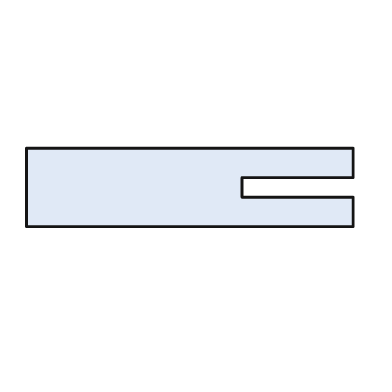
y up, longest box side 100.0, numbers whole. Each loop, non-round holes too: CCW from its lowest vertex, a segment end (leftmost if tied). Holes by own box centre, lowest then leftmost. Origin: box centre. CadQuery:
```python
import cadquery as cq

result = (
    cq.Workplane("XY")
    .moveTo(-50.0, -12.0)
    .lineTo(50.0, -12.0)
    .lineTo(50.0, -3.0)
    .lineTo(16.0, -3.0)
    .lineTo(16.0, 3.0)
    .lineTo(50.0, 3.0)
    .lineTo(50.0, 12.0)
    .lineTo(-50.0, 12.0)
    .close()
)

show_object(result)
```